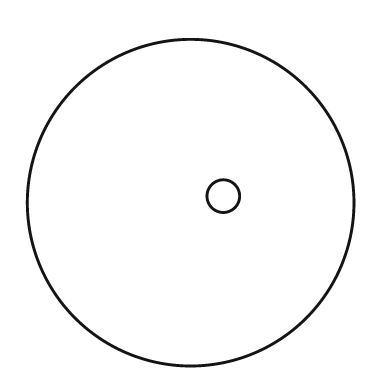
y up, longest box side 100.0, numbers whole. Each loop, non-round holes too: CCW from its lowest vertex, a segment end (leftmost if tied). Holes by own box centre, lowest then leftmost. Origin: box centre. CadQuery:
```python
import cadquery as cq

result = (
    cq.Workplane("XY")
    .moveTo(0.0, 0.0)
    .circle(50.0)
    .moveTo(10.0, 2.0)
    .circle(5.0)
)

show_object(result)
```